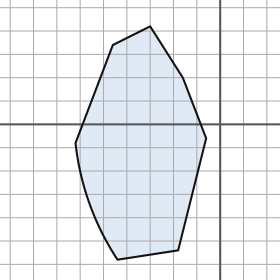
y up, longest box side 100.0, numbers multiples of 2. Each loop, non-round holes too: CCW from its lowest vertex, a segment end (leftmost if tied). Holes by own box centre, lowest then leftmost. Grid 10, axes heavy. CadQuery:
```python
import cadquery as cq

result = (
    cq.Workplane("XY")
    .moveTo(-44.0, -58.0)
    .lineTo(-18.0, -54.0)
    .lineTo(-6.0, -6.0)
    .lineTo(-16.0, 20.0)
    .lineTo(-30.0, 42.0)
    .lineTo(-46.0, 34.0)
    .lineTo(-62.0, -8.0)
    .threePointArc((-56.0, -34.0), (-44.0, -58.0))
    .close()
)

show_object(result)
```